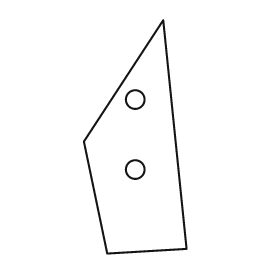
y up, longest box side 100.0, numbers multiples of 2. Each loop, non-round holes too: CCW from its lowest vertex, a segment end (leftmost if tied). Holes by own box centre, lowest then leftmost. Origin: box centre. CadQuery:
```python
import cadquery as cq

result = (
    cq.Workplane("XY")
    .moveTo(-12.0, -50.0)
    .lineTo(22.0, -48.0)
    .lineTo(12.0, 50.0)
    .lineTo(-22.0, -2.0)
    .close()
    .moveTo(0.0, -14.0)
    .circle(4.0)
    .moveTo(0.0, 16.0)
    .circle(4.0)
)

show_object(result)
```